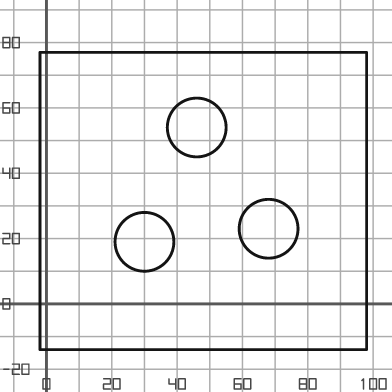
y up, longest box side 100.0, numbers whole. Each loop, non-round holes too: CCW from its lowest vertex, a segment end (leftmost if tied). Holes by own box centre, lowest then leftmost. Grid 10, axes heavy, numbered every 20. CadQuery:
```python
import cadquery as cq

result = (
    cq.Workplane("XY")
    .moveTo(-2.0, -14.0)
    .lineTo(98.0, -14.0)
    .lineTo(98.0, 77.0)
    .lineTo(-2.0, 77.0)
    .close()
    .moveTo(30.0, 19.0)
    .circle(9.0)
    .moveTo(68.0, 23.0)
    .circle(9.0)
    .moveTo(46.0, 54.0)
    .circle(9.0)
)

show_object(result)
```